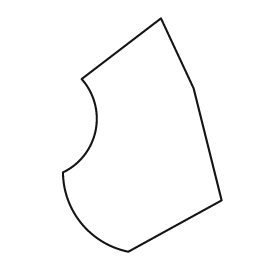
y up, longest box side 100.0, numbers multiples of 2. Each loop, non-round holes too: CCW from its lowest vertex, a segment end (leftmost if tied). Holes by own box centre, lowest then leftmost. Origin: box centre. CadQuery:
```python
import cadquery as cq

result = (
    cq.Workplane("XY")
    .moveTo(-6.0, -50.0)
    .lineTo(34.0, -28.0)
    .lineTo(22.0, 20.0)
    .lineTo(8.0, 50.0)
    .lineTo(-26.0, 24.0)
    .threePointArc((-20.0, 2.0), (-34.0, -16.0))
    .threePointArc((-26.0, -38.0), (-6.0, -50.0))
    .close()
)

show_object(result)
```